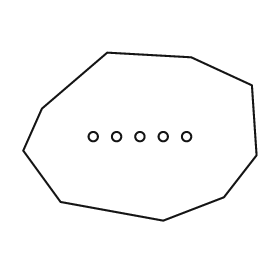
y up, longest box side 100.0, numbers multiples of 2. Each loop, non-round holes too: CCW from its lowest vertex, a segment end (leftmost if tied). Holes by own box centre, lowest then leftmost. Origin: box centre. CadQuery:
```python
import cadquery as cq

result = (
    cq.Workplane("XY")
    .moveTo(10.0, -36.0)
    .lineTo(36.0, -26.0)
    .lineTo(50.0, -8.0)
    .lineTo(48.0, 22.0)
    .lineTo(22.0, 34.0)
    .lineTo(-14.0, 36.0)
    .lineTo(-42.0, 12.0)
    .lineTo(-50.0, -6.0)
    .lineTo(-34.0, -28.0)
    .close()
    .moveTo(-20.0, 0.0)
    .circle(2.0)
    .moveTo(-10.0, 0.0)
    .circle(2.0)
    .moveTo(0.0, 0.0)
    .circle(2.0)
    .moveTo(10.0, 0.0)
    .circle(2.0)
    .moveTo(20.0, 0.0)
    .circle(2.0)
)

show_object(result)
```